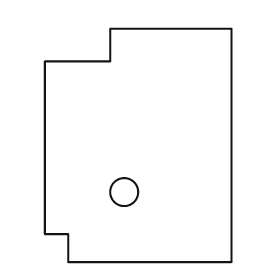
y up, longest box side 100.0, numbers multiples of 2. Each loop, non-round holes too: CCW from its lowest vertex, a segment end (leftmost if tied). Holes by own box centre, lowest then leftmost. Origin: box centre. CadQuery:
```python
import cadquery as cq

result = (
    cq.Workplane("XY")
    .moveTo(-30.0, -50.0)
    .lineTo(40.0, -50.0)
    .lineTo(40.0, 50.0)
    .lineTo(-12.0, 50.0)
    .lineTo(-12.0, 36.0)
    .lineTo(-40.0, 36.0)
    .lineTo(-40.0, -38.0)
    .lineTo(-30.0, -38.0)
    .close()
    .moveTo(-6.0, -20.0)
    .circle(6.0)
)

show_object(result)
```